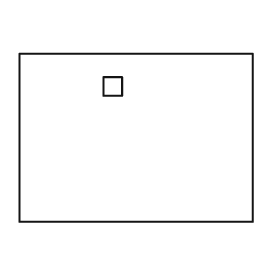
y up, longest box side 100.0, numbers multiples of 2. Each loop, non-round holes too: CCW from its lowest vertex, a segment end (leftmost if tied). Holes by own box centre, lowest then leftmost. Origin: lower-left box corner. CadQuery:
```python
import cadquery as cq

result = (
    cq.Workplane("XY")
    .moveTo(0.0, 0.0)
    .lineTo(100.0, 0.0)
    .lineTo(100.0, 72.0)
    .lineTo(0.0, 72.0)
    .close()
    .moveTo(36.0, 54.0)
    .lineTo(44.0, 54.0)
    .lineTo(44.0, 62.0)
    .lineTo(36.0, 62.0)
    .close()
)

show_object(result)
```